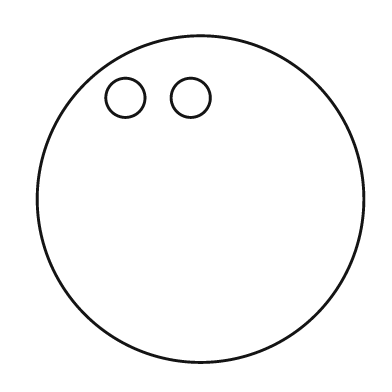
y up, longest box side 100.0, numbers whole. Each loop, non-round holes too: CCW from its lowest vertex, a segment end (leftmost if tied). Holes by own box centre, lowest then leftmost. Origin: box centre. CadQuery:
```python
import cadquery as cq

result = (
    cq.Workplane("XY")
    .moveTo(0.0, 0.0)
    .circle(50.0)
    .moveTo(-23.0, 31.0)
    .circle(6.0)
    .moveTo(-3.0, 31.0)
    .circle(6.0)
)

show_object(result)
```